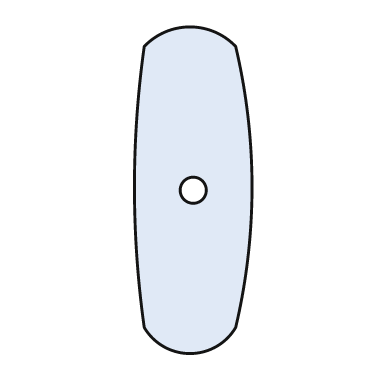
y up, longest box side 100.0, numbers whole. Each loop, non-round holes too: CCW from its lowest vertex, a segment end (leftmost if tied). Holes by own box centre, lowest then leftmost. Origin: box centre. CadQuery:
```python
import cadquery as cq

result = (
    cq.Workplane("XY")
    .moveTo(-15.0, -42.0)
    .threePointArc((-1.0, -50.0), (13.0, -42.0))
    .threePointArc((18.0, 1.0), (13.0, 44.0))
    .threePointArc((-1.0, 50.0), (-15.0, 44.0))
    .threePointArc((-18.0, 1.0), (-15.0, -42.0))
    .close()
    .moveTo(0.0, 0.0)
    .circle(4.0)
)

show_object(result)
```